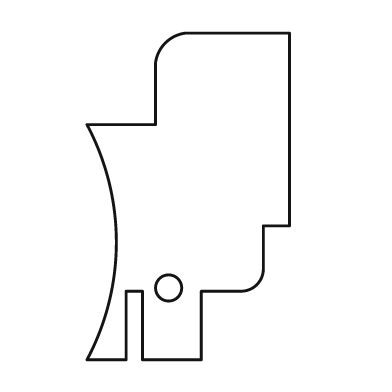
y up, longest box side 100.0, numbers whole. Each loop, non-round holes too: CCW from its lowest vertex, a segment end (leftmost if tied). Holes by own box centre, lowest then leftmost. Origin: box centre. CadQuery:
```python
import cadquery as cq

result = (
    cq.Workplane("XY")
    .moveTo(-31.0, -50.0)
    .lineTo(-19.0, -50.0)
    .lineTo(-19.0, -29.0)
    .lineTo(-14.0, -29.0)
    .lineTo(-14.0, -50.0)
    .lineTo(4.0, -50.0)
    .lineTo(4.0, -29.0)
    .lineTo(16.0, -29.0)
    .threePointArc((21.0, -27.0), (23.0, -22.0))
    .lineTo(23.0, -9.0)
    .lineTo(31.0, -9.0)
    .lineTo(31.0, 50.0)
    .lineTo(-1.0, 50.0)
    .threePointArc((-7.0, 47.0), (-10.0, 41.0))
    .lineTo(-10.0, 22.0)
    .lineTo(-31.0, 22.0)
    .threePointArc((-22.0, -14.0), (-31.0, -50.0))
    .close()
    .moveTo(-6.0, -28.0)
    .circle(4.0)
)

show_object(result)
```